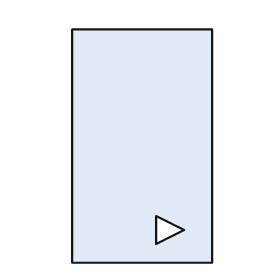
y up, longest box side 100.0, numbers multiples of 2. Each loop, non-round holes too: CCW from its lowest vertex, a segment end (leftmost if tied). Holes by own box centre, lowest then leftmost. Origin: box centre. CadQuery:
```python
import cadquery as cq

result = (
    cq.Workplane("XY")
    .moveTo(-30.0, -50.0)
    .lineTo(30.0, -50.0)
    .lineTo(30.0, 50.0)
    .lineTo(-30.0, 50.0)
    .close()
    .moveTo(6.0, -42.0)
    .lineTo(18.0, -36.0)
    .lineTo(6.0, -30.0)
    .close()
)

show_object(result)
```